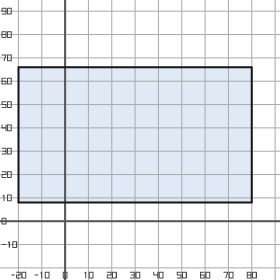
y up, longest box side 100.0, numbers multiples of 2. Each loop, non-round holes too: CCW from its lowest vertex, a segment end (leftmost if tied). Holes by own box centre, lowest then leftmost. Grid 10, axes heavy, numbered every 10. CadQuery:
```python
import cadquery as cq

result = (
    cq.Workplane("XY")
    .moveTo(-20.0, 8.0)
    .lineTo(80.0, 8.0)
    .lineTo(80.0, 66.0)
    .lineTo(-20.0, 66.0)
    .close()
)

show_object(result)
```